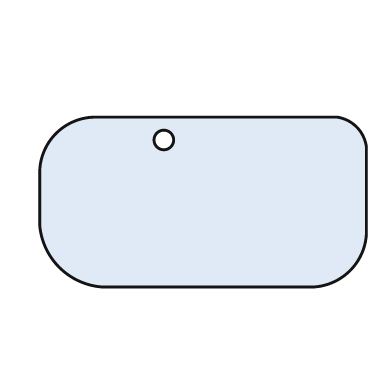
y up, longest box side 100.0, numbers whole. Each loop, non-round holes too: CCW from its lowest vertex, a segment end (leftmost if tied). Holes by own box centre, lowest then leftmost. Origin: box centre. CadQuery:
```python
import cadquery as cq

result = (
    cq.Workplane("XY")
    .moveTo(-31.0, -26.0)
    .lineTo(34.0, -26.0)
    .threePointArc((45.0, -21.0), (50.0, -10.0))
    .lineTo(50.0, 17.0)
    .threePointArc((47.0, 23.0), (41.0, 26.0))
    .lineTo(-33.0, 26.0)
    .threePointArc((-45.0, 21.0), (-50.0, 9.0))
    .lineTo(-50.0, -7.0)
    .threePointArc((-44.0, -20.0), (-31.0, -26.0))
    .close()
    .moveTo(-12.0, 19.0)
    .circle(3.0)
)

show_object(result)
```